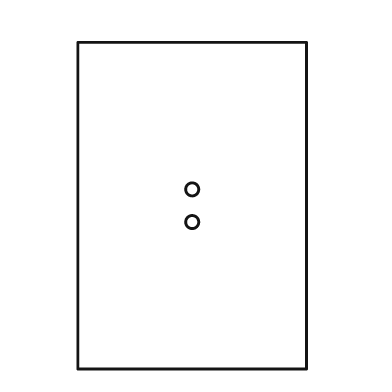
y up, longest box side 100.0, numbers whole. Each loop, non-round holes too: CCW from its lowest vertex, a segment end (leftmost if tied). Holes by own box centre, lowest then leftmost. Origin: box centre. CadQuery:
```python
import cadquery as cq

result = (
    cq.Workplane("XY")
    .moveTo(-35.0, -50.0)
    .lineTo(35.0, -50.0)
    .lineTo(35.0, 50.0)
    .lineTo(-35.0, 50.0)
    .close()
    .moveTo(0.0, -5.0)
    .circle(2.0)
    .moveTo(0.0, 5.0)
    .circle(2.0)
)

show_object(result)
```